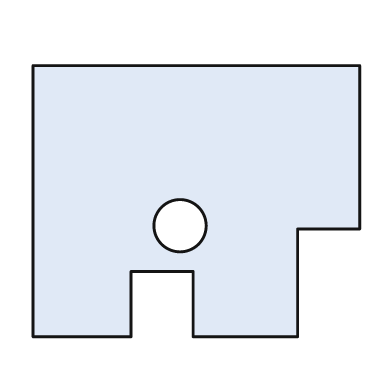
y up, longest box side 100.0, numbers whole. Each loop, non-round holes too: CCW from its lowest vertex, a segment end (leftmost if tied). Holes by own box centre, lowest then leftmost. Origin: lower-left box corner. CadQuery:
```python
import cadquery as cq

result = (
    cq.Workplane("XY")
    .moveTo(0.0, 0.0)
    .lineTo(30.0, 0.0)
    .lineTo(30.0, 20.0)
    .lineTo(49.0, 20.0)
    .lineTo(49.0, 0.0)
    .lineTo(81.0, 0.0)
    .lineTo(81.0, 33.0)
    .lineTo(100.0, 33.0)
    .lineTo(100.0, 83.0)
    .lineTo(0.0, 83.0)
    .close()
    .moveTo(45.0, 34.0)
    .circle(8.0)
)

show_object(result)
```